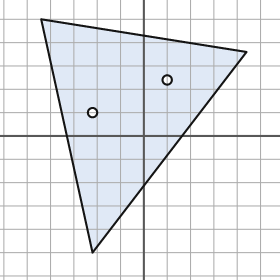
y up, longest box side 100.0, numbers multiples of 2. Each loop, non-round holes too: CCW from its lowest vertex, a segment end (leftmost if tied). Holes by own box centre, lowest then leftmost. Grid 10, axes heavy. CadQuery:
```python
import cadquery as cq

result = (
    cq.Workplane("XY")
    .moveTo(-22.0, -50.0)
    .lineTo(44.0, 36.0)
    .lineTo(-44.0, 50.0)
    .close()
    .moveTo(-22.0, 10.0)
    .circle(2.0)
    .moveTo(10.0, 24.0)
    .circle(2.0)
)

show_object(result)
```